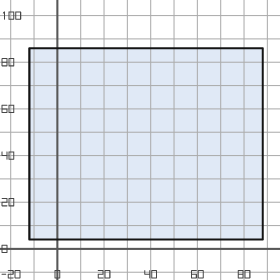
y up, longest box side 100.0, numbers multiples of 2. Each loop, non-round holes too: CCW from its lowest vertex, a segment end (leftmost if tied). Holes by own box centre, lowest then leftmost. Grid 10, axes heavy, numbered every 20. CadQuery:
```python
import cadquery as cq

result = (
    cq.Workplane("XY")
    .moveTo(-12.0, 4.0)
    .lineTo(88.0, 4.0)
    .lineTo(88.0, 86.0)
    .lineTo(-12.0, 86.0)
    .close()
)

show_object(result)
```